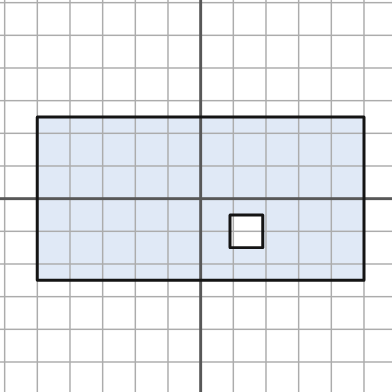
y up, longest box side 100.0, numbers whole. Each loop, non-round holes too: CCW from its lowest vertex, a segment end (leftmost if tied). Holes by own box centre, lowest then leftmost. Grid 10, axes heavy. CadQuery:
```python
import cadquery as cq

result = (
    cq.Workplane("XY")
    .moveTo(-50.0, -25.0)
    .lineTo(50.0, -25.0)
    .lineTo(50.0, 25.0)
    .lineTo(-50.0, 25.0)
    .close()
    .moveTo(9.0, -15.0)
    .lineTo(19.0, -15.0)
    .lineTo(19.0, -5.0)
    .lineTo(9.0, -5.0)
    .close()
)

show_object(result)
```